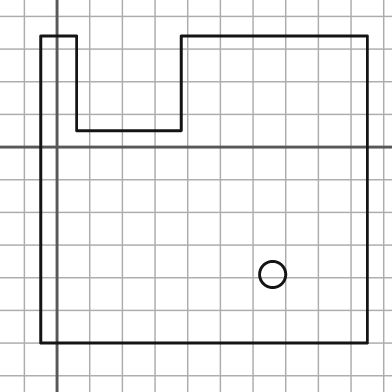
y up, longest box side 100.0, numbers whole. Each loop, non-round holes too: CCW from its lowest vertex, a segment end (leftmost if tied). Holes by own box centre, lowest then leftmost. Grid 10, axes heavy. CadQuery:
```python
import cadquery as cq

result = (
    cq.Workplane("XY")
    .moveTo(-5.0, -60.0)
    .lineTo(95.0, -60.0)
    .lineTo(95.0, 34.0)
    .lineTo(38.0, 34.0)
    .lineTo(38.0, 5.0)
    .lineTo(6.0, 5.0)
    .lineTo(6.0, 34.0)
    .lineTo(-5.0, 34.0)
    .close()
    .moveTo(66.0, -39.0)
    .circle(4.0)
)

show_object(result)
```